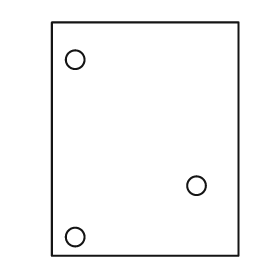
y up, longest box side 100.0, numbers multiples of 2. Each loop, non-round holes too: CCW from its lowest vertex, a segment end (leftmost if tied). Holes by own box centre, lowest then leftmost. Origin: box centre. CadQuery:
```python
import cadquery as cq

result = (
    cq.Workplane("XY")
    .moveTo(-40.0, -50.0)
    .lineTo(40.0, -50.0)
    .lineTo(40.0, 50.0)
    .lineTo(-40.0, 50.0)
    .close()
    .moveTo(-30.0, -42.0)
    .circle(4.0)
    .moveTo(22.0, -20.0)
    .circle(4.0)
    .moveTo(-30.0, 34.0)
    .circle(4.0)
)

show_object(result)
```